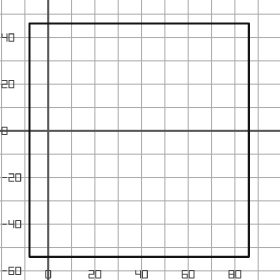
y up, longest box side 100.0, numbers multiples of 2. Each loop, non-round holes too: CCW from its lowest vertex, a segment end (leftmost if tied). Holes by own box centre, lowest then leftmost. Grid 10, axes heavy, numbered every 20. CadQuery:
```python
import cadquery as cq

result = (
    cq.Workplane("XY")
    .moveTo(-8.0, -54.0)
    .lineTo(86.0, -54.0)
    .lineTo(86.0, 46.0)
    .lineTo(-8.0, 46.0)
    .close()
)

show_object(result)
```